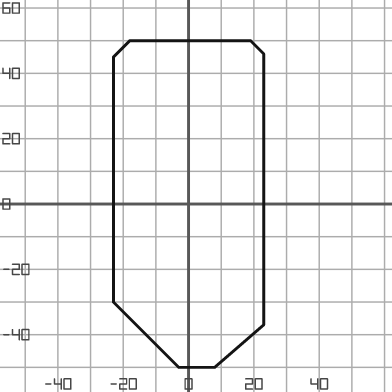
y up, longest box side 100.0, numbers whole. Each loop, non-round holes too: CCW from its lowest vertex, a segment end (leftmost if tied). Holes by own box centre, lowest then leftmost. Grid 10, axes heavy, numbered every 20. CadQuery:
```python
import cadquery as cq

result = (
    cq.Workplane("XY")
    .moveTo(-3.0, -50.0)
    .lineTo(8.0, -50.0)
    .lineTo(23.0, -37.0)
    .lineTo(23.0, 46.0)
    .lineTo(19.0, 50.0)
    .lineTo(-18.0, 50.0)
    .lineTo(-23.0, 45.0)
    .lineTo(-23.0, -30.0)
    .close()
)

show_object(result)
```